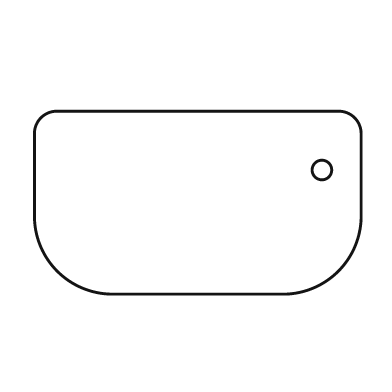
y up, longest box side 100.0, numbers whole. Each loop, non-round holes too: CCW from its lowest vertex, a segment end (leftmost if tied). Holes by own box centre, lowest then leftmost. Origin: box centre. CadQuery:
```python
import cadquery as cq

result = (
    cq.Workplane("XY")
    .moveTo(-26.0, -28.0)
    .lineTo(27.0, -28.0)
    .threePointArc((43.0, -21.0), (50.0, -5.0))
    .lineTo(50.0, 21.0)
    .threePointArc((48.0, 26.0), (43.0, 28.0))
    .lineTo(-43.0, 28.0)
    .threePointArc((-48.0, 26.0), (-50.0, 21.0))
    .lineTo(-50.0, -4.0)
    .threePointArc((-43.0, -21.0), (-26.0, -28.0))
    .close()
    .moveTo(38.0, 10.0)
    .circle(3.0)
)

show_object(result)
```